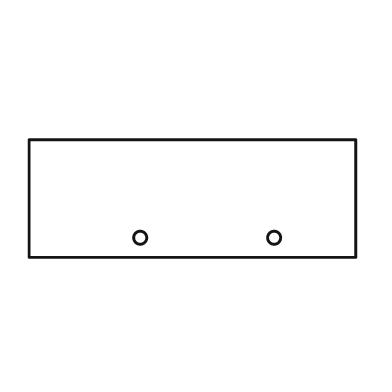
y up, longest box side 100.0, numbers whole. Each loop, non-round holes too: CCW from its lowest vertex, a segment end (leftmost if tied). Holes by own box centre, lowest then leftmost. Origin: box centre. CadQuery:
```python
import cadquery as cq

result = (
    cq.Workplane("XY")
    .moveTo(-50.0, -18.0)
    .lineTo(50.0, -18.0)
    .lineTo(50.0, 18.0)
    .lineTo(-50.0, 18.0)
    .close()
    .moveTo(-16.0, -12.0)
    .circle(2.0)
    .moveTo(25.0, -12.0)
    .circle(2.0)
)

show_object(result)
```